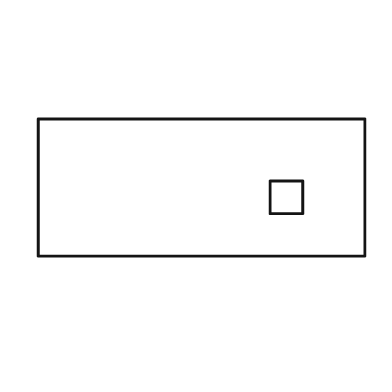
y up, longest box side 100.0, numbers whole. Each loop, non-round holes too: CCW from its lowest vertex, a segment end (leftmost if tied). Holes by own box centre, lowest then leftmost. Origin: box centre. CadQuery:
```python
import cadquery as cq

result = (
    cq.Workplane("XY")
    .moveTo(-50.0, -21.0)
    .lineTo(50.0, -21.0)
    .lineTo(50.0, 21.0)
    .lineTo(-50.0, 21.0)
    .close()
    .moveTo(21.0, -8.0)
    .lineTo(31.0, -8.0)
    .lineTo(31.0, 2.0)
    .lineTo(21.0, 2.0)
    .close()
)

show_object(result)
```